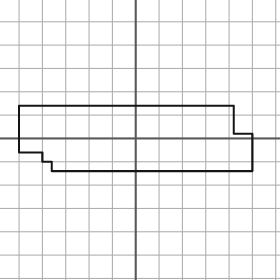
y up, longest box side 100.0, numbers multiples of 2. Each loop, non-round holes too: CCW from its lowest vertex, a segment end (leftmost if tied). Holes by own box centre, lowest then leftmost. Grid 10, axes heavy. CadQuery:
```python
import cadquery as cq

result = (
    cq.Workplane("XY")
    .moveTo(-36.0, -14.0)
    .lineTo(50.0, -14.0)
    .lineTo(50.0, 2.0)
    .lineTo(42.0, 2.0)
    .lineTo(42.0, 14.0)
    .lineTo(-50.0, 14.0)
    .lineTo(-50.0, -6.0)
    .lineTo(-40.0, -6.0)
    .lineTo(-40.0, -10.0)
    .lineTo(-36.0, -10.0)
    .close()
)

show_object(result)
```